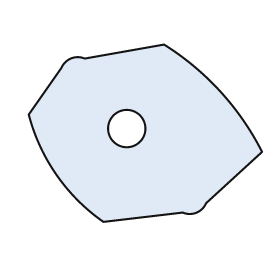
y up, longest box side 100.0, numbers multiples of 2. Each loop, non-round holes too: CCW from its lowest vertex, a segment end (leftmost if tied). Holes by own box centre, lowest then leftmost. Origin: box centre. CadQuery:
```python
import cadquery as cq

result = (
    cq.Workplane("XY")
    .moveTo(-18.0, -38.0)
    .lineTo(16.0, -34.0)
    .threePointArc((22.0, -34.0), (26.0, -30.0))
    .lineTo(50.0, -8.0)
    .threePointArc((32.0, 18.0), (8.0, 38.0))
    .lineTo(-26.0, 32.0)
    .threePointArc((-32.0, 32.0), (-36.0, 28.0))
    .lineTo(-50.0, 8.0)
    .threePointArc((-38.0, -18.0), (-18.0, -38.0))
    .close()
    .moveTo(-8.0, 2.0)
    .circle(8.0)
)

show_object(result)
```